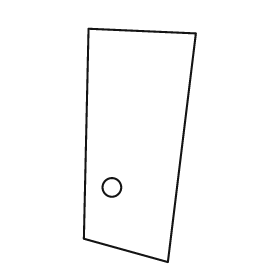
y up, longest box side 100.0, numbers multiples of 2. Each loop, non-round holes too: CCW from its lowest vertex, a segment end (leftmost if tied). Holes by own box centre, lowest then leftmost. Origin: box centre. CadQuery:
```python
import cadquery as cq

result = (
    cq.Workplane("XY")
    .moveTo(12.0, -50.0)
    .lineTo(24.0, 48.0)
    .lineTo(-22.0, 50.0)
    .lineTo(-24.0, -40.0)
    .close()
    .moveTo(-12.0, -18.0)
    .circle(4.0)
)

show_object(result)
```